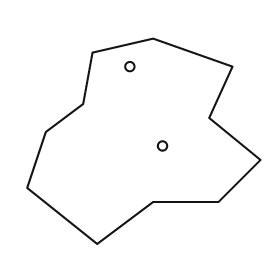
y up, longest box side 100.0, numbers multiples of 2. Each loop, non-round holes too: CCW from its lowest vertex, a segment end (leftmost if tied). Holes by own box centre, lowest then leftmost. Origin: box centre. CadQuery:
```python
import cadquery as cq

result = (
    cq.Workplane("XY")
    .moveTo(-20.0, -44.0)
    .lineTo(4.0, -26.0)
    .lineTo(32.0, -26.0)
    .lineTo(50.0, -8.0)
    .lineTo(28.0, 10.0)
    .lineTo(38.0, 32.0)
    .lineTo(4.0, 44.0)
    .lineTo(-22.0, 38.0)
    .lineTo(-26.0, 16.0)
    .lineTo(-42.0, 4.0)
    .lineTo(-50.0, -20.0)
    .close()
    .moveTo(8.0, -2.0)
    .circle(2.0)
    .moveTo(-6.0, 32.0)
    .circle(2.0)
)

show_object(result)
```